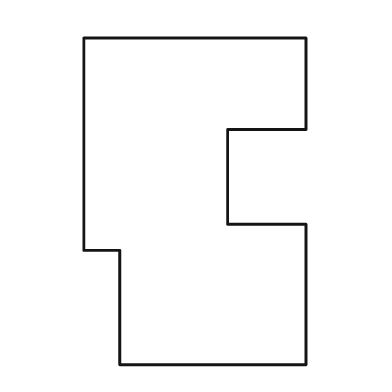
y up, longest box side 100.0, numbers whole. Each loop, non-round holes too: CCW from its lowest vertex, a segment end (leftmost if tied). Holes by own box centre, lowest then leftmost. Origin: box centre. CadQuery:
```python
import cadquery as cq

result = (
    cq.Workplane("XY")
    .moveTo(-23.0, -50.0)
    .lineTo(34.0, -50.0)
    .lineTo(34.0, -7.0)
    .lineTo(10.0, -7.0)
    .lineTo(10.0, 22.0)
    .lineTo(34.0, 22.0)
    .lineTo(34.0, 50.0)
    .lineTo(-34.0, 50.0)
    .lineTo(-34.0, -15.0)
    .lineTo(-23.0, -15.0)
    .close()
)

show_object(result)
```